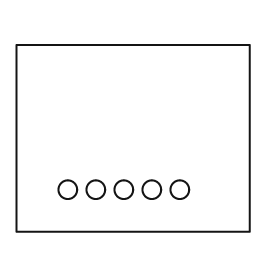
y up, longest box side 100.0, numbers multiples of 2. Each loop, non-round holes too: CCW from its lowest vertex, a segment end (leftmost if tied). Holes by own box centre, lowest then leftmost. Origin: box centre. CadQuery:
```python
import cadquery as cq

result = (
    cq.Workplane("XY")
    .moveTo(-50.0, -40.0)
    .lineTo(50.0, -40.0)
    .lineTo(50.0, 40.0)
    .lineTo(-50.0, 40.0)
    .close()
    .moveTo(-28.0, -22.0)
    .circle(4.0)
    .moveTo(-16.0, -22.0)
    .circle(4.0)
    .moveTo(-4.0, -22.0)
    .circle(4.0)
    .moveTo(8.0, -22.0)
    .circle(4.0)
    .moveTo(20.0, -22.0)
    .circle(4.0)
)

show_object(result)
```